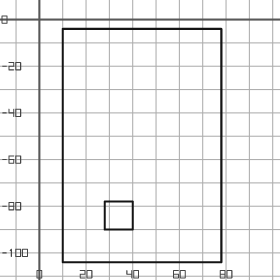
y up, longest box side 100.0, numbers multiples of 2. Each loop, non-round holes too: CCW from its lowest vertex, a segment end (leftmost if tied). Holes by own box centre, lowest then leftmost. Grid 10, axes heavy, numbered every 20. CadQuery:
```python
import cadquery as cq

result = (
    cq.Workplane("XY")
    .moveTo(10.0, -104.0)
    .lineTo(78.0, -104.0)
    .lineTo(78.0, -4.0)
    .lineTo(10.0, -4.0)
    .close()
    .moveTo(28.0, -90.0)
    .lineTo(40.0, -90.0)
    .lineTo(40.0, -78.0)
    .lineTo(28.0, -78.0)
    .close()
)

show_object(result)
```